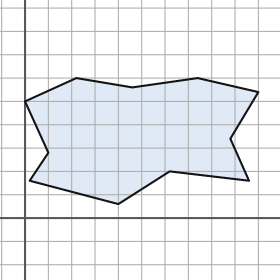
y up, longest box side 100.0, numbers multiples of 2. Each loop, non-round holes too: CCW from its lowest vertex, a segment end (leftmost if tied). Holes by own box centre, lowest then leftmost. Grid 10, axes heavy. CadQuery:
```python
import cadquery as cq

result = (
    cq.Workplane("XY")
    .moveTo(40.0, 6.0)
    .lineTo(62.0, 20.0)
    .lineTo(96.0, 16.0)
    .lineTo(88.0, 34.0)
    .lineTo(100.0, 54.0)
    .lineTo(74.0, 60.0)
    .lineTo(46.0, 56.0)
    .lineTo(22.0, 60.0)
    .lineTo(0.0, 50.0)
    .lineTo(10.0, 28.0)
    .lineTo(2.0, 16.0)
    .close()
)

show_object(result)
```